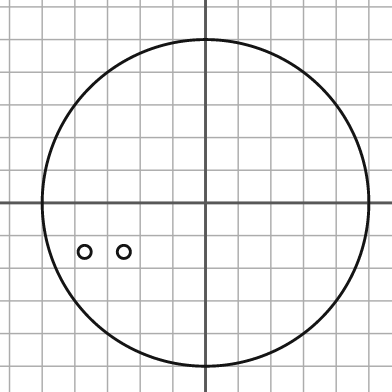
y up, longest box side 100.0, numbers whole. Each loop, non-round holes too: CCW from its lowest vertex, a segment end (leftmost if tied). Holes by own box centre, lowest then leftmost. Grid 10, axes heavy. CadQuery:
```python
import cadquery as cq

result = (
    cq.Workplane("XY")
    .moveTo(0.0, 0.0)
    .circle(50.0)
    .moveTo(-37.0, -15.0)
    .circle(2.0)
    .moveTo(-25.0, -15.0)
    .circle(2.0)
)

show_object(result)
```